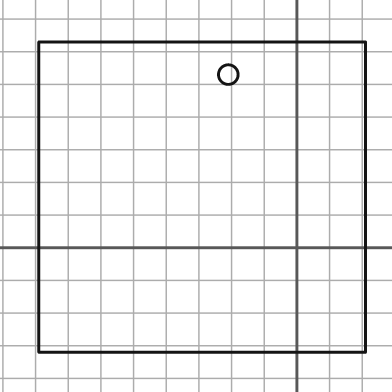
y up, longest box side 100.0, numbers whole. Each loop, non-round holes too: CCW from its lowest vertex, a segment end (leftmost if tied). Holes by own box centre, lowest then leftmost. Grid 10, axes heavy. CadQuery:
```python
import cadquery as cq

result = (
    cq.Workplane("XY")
    .moveTo(-79.0, -32.0)
    .lineTo(21.0, -32.0)
    .lineTo(21.0, 63.0)
    .lineTo(-79.0, 63.0)
    .close()
    .moveTo(-21.0, 53.0)
    .circle(3.0)
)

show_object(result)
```